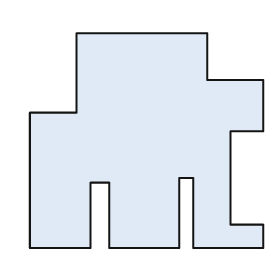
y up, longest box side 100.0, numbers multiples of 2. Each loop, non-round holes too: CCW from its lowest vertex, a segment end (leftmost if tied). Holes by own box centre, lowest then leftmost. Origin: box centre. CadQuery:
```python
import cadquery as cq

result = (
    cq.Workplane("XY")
    .moveTo(-50.0, -46.0)
    .lineTo(-24.0, -46.0)
    .lineTo(-24.0, -18.0)
    .lineTo(-16.0, -18.0)
    .lineTo(-16.0, -46.0)
    .lineTo(14.0, -46.0)
    .lineTo(14.0, -16.0)
    .lineTo(20.0, -16.0)
    .lineTo(20.0, -46.0)
    .lineTo(50.0, -46.0)
    .lineTo(50.0, -36.0)
    .lineTo(36.0, -36.0)
    .lineTo(36.0, 4.0)
    .lineTo(50.0, 4.0)
    .lineTo(50.0, 26.0)
    .lineTo(26.0, 26.0)
    .lineTo(26.0, 46.0)
    .lineTo(-30.0, 46.0)
    .lineTo(-30.0, 12.0)
    .lineTo(-50.0, 12.0)
    .close()
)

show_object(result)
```